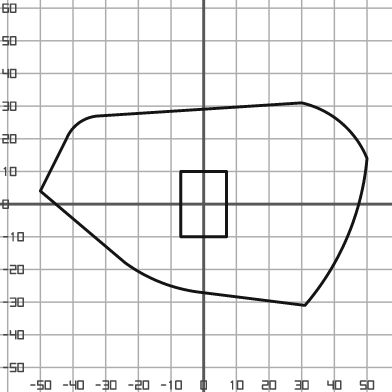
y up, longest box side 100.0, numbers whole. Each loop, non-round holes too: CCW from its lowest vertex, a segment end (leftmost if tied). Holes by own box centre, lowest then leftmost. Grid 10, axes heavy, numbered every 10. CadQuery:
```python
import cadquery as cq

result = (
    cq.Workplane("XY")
    .moveTo(31.0, -31.0)
    .threePointArc((44.0, -10.0), (50.0, 14.0))
    .threePointArc((42.0, 25.0), (30.0, 31.0))
    .lineTo(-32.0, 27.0)
    .threePointArc((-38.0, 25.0), (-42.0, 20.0))
    .lineTo(-50.0, 4.0)
    .lineTo(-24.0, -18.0)
    .threePointArc((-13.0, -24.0), (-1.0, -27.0))
    .close()
    .moveTo(-7.0, -10.0)
    .lineTo(7.0, -10.0)
    .lineTo(7.0, 10.0)
    .lineTo(-7.0, 10.0)
    .close()
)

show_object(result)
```